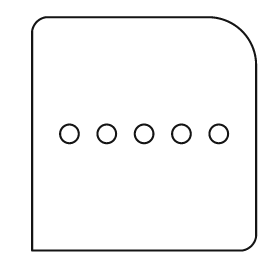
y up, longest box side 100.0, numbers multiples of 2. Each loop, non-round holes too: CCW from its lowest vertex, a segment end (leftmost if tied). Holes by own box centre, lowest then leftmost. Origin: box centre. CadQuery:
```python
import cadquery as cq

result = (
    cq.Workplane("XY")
    .moveTo(-48.0, -50.0)
    .lineTo(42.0, -50.0)
    .threePointArc((46.0, -48.0), (48.0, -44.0))
    .lineTo(48.0, 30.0)
    .threePointArc((42.0, 44.0), (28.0, 50.0))
    .lineTo(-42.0, 50.0)
    .threePointArc((-46.0, 48.0), (-48.0, 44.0))
    .close()
    .moveTo(-32.0, 0.0)
    .circle(4.0)
    .moveTo(-16.0, 0.0)
    .circle(4.0)
    .moveTo(0.0, 0.0)
    .circle(4.0)
    .moveTo(16.0, 0.0)
    .circle(4.0)
    .moveTo(32.0, 0.0)
    .circle(4.0)
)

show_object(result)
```